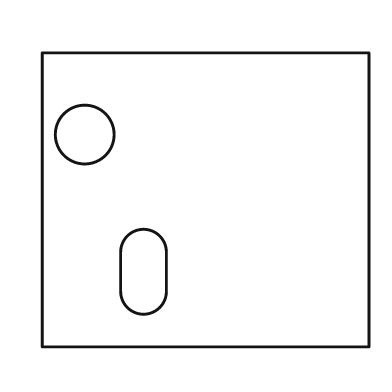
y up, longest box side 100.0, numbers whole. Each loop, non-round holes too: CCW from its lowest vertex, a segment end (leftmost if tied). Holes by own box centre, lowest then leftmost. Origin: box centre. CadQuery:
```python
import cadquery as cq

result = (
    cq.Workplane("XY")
    .moveTo(-50.0, -45.0)
    .lineTo(50.0, -45.0)
    .lineTo(50.0, 45.0)
    .lineTo(-50.0, 45.0)
    .close()
    .moveTo(-26.0, -28.0)
    .threePointArc((-19.0, -35.0), (-12.0, -28.0))
    .lineTo(-12.0, -16.0)
    .threePointArc((-19.0, -9.0), (-26.0, -16.0))
    .close()
    .moveTo(-37.0, 20.0)
    .circle(9.0)
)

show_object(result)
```